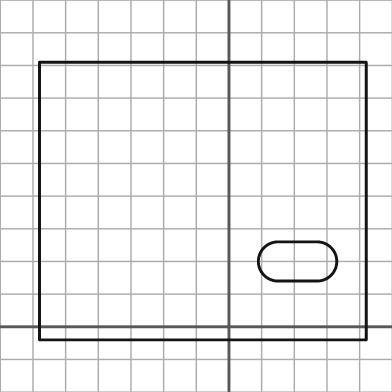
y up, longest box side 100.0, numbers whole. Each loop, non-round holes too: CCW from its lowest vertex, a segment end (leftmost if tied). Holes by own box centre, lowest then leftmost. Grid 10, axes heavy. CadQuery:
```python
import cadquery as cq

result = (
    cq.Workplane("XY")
    .moveTo(-58.0, -4.0)
    .lineTo(42.0, -4.0)
    .lineTo(42.0, 81.0)
    .lineTo(-58.0, 81.0)
    .close()
    .moveTo(15.0, 14.0)
    .lineTo(27.0, 14.0)
    .threePointArc((33.0, 20.0), (27.0, 26.0))
    .lineTo(15.0, 26.0)
    .threePointArc((9.0, 20.0), (15.0, 14.0))
    .close()
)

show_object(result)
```